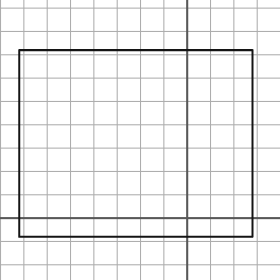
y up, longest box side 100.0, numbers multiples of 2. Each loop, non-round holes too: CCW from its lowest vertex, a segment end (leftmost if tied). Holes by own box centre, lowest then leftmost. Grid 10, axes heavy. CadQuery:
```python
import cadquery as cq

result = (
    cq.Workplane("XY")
    .moveTo(-72.0, -8.0)
    .lineTo(28.0, -8.0)
    .lineTo(28.0, 72.0)
    .lineTo(-72.0, 72.0)
    .close()
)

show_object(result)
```